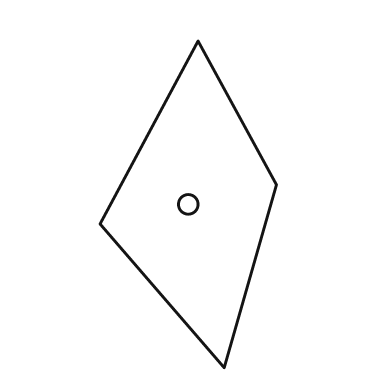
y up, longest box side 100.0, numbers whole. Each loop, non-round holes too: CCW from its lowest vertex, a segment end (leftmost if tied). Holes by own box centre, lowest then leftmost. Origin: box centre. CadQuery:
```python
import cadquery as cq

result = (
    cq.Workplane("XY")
    .moveTo(11.0, -50.0)
    .lineTo(27.0, 6.0)
    .lineTo(3.0, 50.0)
    .lineTo(-27.0, -6.0)
    .close()
    .moveTo(0.0, 0.0)
    .circle(3.0)
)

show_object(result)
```